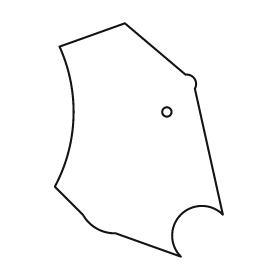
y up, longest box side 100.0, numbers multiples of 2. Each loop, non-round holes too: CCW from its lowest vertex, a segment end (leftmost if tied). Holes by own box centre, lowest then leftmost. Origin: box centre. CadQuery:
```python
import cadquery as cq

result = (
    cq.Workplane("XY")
    .moveTo(18.0, -50.0)
    .threePointArc((18.0, -32.0), (36.0, -32.0))
    .lineTo(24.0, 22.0)
    .threePointArc((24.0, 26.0), (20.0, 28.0))
    .lineTo(-6.0, 50.0)
    .lineTo(-34.0, 40.0)
    .threePointArc((-28.0, 10.0), (-36.0, -20.0))
    .lineTo(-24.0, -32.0)
    .threePointArc((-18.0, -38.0), (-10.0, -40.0))
    .close()
    .moveTo(12.0, 12.0)
    .circle(2.0)
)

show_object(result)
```